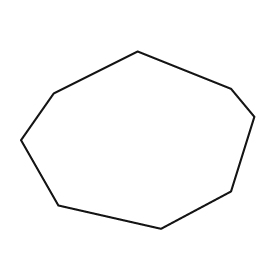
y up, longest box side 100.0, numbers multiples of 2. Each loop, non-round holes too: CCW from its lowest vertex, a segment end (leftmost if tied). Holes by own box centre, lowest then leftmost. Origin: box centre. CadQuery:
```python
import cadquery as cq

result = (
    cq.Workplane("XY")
    .moveTo(10.0, -38.0)
    .lineTo(40.0, -22.0)
    .lineTo(50.0, 10.0)
    .lineTo(40.0, 22.0)
    .lineTo(0.0, 38.0)
    .lineTo(-36.0, 20.0)
    .lineTo(-50.0, 0.0)
    .lineTo(-34.0, -28.0)
    .close()
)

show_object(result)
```